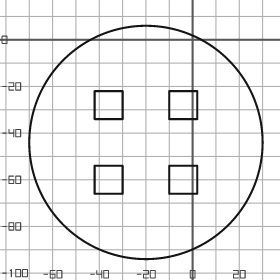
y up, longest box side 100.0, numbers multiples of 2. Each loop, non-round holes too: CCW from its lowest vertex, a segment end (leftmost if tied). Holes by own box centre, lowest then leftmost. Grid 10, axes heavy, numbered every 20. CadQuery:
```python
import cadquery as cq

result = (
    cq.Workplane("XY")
    .moveTo(-20.0, -44.0)
    .circle(50.0)
    .moveTo(-42.0, -66.0)
    .lineTo(-30.0, -66.0)
    .lineTo(-30.0, -54.0)
    .lineTo(-42.0, -54.0)
    .close()
    .moveTo(-10.0, -66.0)
    .lineTo(2.0, -66.0)
    .lineTo(2.0, -54.0)
    .lineTo(-10.0, -54.0)
    .close()
    .moveTo(-42.0, -34.0)
    .lineTo(-30.0, -34.0)
    .lineTo(-30.0, -22.0)
    .lineTo(-42.0, -22.0)
    .close()
    .moveTo(-10.0, -34.0)
    .lineTo(2.0, -34.0)
    .lineTo(2.0, -22.0)
    .lineTo(-10.0, -22.0)
    .close()
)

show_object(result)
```